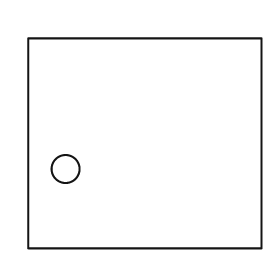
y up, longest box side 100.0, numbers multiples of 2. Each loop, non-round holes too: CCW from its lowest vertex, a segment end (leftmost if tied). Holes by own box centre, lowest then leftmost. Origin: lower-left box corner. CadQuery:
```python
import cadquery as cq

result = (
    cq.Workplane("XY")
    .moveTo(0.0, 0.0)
    .lineTo(100.0, 0.0)
    .lineTo(100.0, 90.0)
    .lineTo(0.0, 90.0)
    .close()
    .moveTo(16.0, 34.0)
    .circle(6.0)
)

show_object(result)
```